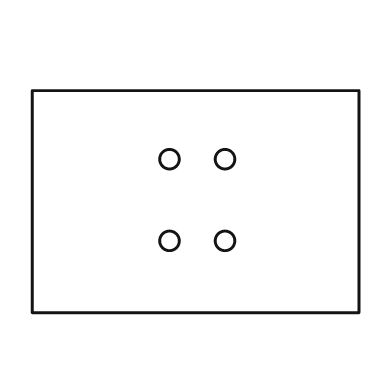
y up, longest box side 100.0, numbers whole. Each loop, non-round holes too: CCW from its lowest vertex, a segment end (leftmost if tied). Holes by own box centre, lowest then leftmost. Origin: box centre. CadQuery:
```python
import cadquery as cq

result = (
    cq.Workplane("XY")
    .moveTo(-50.0, -34.0)
    .lineTo(50.0, -34.0)
    .lineTo(50.0, 34.0)
    .lineTo(-50.0, 34.0)
    .close()
    .moveTo(-8.0, -12.0)
    .circle(3.0)
    .moveTo(9.0, -12.0)
    .circle(3.0)
    .moveTo(-8.0, 13.0)
    .circle(3.0)
    .moveTo(9.0, 13.0)
    .circle(3.0)
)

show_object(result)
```